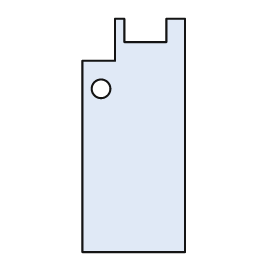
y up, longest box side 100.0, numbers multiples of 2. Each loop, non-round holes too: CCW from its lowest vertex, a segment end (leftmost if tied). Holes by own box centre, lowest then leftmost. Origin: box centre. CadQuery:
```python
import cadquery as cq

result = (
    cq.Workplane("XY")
    .moveTo(-22.0, -50.0)
    .lineTo(22.0, -50.0)
    .lineTo(22.0, 50.0)
    .lineTo(14.0, 50.0)
    .lineTo(14.0, 40.0)
    .lineTo(-4.0, 40.0)
    .lineTo(-4.0, 50.0)
    .lineTo(-8.0, 50.0)
    .lineTo(-8.0, 32.0)
    .lineTo(-22.0, 32.0)
    .close()
    .moveTo(-14.0, 20.0)
    .circle(4.0)
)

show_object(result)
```